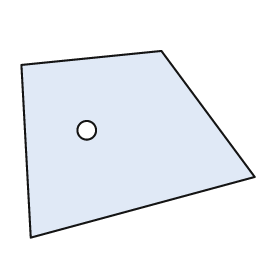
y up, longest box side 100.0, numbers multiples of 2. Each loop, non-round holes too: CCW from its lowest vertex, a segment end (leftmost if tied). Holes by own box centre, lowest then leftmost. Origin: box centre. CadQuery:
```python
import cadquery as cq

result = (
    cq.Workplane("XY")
    .moveTo(-46.0, -40.0)
    .lineTo(50.0, -14.0)
    .lineTo(10.0, 40.0)
    .lineTo(-50.0, 34.0)
    .close()
    .moveTo(-22.0, 6.0)
    .circle(4.0)
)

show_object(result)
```